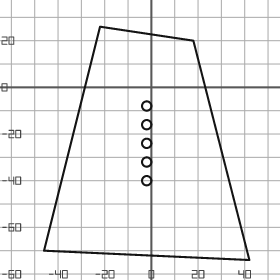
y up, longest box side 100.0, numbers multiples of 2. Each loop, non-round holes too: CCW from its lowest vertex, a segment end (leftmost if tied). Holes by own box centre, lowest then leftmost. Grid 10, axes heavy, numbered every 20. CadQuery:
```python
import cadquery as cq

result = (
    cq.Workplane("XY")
    .moveTo(42.0, -74.0)
    .lineTo(18.0, 20.0)
    .lineTo(-22.0, 26.0)
    .lineTo(-46.0, -70.0)
    .close()
    .moveTo(-2.0, -40.0)
    .circle(2.0)
    .moveTo(-2.0, -32.0)
    .circle(2.0)
    .moveTo(-2.0, -24.0)
    .circle(2.0)
    .moveTo(-2.0, -16.0)
    .circle(2.0)
    .moveTo(-2.0, -8.0)
    .circle(2.0)
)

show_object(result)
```